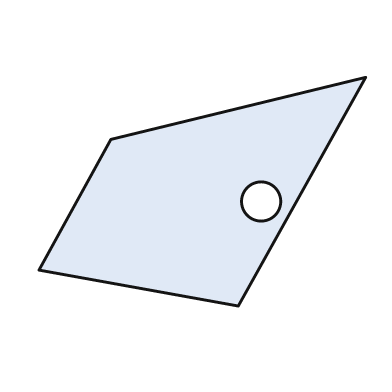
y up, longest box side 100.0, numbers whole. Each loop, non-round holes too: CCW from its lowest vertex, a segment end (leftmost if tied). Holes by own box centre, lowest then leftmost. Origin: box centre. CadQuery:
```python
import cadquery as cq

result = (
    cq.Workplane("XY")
    .moveTo(11.0, -35.0)
    .lineTo(50.0, 35.0)
    .lineTo(-28.0, 16.0)
    .lineTo(-50.0, -24.0)
    .close()
    .moveTo(18.0, -3.0)
    .circle(6.0)
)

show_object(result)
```